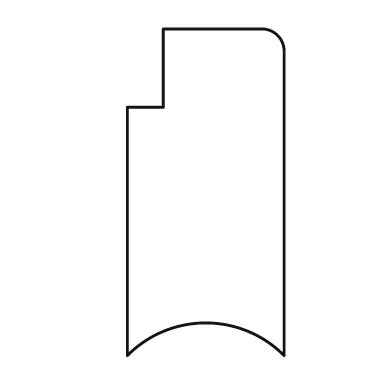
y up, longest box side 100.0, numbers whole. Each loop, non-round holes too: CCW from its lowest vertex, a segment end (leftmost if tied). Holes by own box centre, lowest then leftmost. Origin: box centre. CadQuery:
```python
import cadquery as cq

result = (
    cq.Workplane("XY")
    .moveTo(-24.0, -50.0)
    .threePointArc((0.0, -40.0), (24.0, -50.0))
    .lineTo(24.0, 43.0)
    .threePointArc((22.0, 48.0), (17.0, 50.0))
    .lineTo(-13.0, 50.0)
    .lineTo(-13.0, 26.0)
    .lineTo(-24.0, 26.0)
    .close()
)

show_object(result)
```